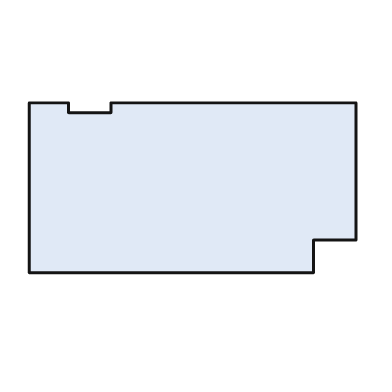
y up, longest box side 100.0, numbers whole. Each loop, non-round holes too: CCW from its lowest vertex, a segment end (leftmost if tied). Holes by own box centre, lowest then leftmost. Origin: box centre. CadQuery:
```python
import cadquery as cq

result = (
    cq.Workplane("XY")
    .moveTo(-50.0, -26.0)
    .lineTo(37.0, -26.0)
    .lineTo(37.0, -16.0)
    .lineTo(50.0, -16.0)
    .lineTo(50.0, 26.0)
    .lineTo(-25.0, 26.0)
    .lineTo(-25.0, 23.0)
    .lineTo(-38.0, 23.0)
    .lineTo(-38.0, 26.0)
    .lineTo(-50.0, 26.0)
    .close()
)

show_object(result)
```